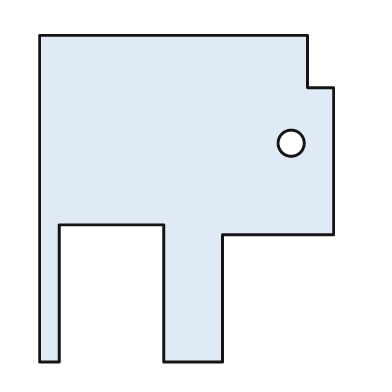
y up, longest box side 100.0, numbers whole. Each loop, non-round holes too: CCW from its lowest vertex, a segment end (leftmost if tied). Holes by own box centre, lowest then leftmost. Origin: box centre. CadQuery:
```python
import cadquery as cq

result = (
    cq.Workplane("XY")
    .moveTo(-45.0, -50.0)
    .lineTo(-39.0, -50.0)
    .lineTo(-39.0, -8.0)
    .lineTo(-7.0, -8.0)
    .lineTo(-7.0, -50.0)
    .lineTo(11.0, -50.0)
    .lineTo(11.0, -11.0)
    .lineTo(45.0, -11.0)
    .lineTo(45.0, 34.0)
    .lineTo(37.0, 34.0)
    .lineTo(37.0, 50.0)
    .lineTo(-45.0, 50.0)
    .close()
    .moveTo(32.0, 17.0)
    .circle(4.0)
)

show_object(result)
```